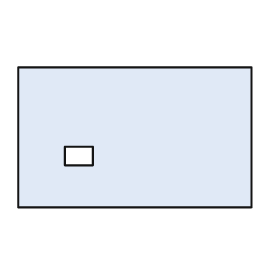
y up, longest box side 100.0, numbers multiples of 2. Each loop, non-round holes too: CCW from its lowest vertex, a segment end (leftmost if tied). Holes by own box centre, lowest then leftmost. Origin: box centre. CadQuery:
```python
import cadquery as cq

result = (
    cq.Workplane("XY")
    .moveTo(-50.0, -30.0)
    .lineTo(50.0, -30.0)
    .lineTo(50.0, 30.0)
    .lineTo(-50.0, 30.0)
    .close()
    .moveTo(-30.0, -12.0)
    .lineTo(-18.0, -12.0)
    .lineTo(-18.0, -4.0)
    .lineTo(-30.0, -4.0)
    .close()
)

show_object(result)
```